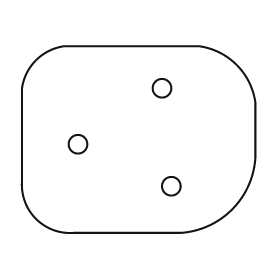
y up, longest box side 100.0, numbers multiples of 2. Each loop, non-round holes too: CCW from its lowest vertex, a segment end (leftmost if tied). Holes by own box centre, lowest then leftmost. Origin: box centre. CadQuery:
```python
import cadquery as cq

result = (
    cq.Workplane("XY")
    .moveTo(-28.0, -40.0)
    .lineTo(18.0, -40.0)
    .threePointArc((40.0, -30.0), (50.0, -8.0))
    .lineTo(50.0, 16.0)
    .threePointArc((42.0, 32.0), (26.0, 40.0))
    .lineTo(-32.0, 40.0)
    .threePointArc((-44.0, 34.0), (-50.0, 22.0))
    .lineTo(-50.0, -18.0)
    .threePointArc((-44.0, -34.0), (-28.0, -40.0))
    .close()
    .moveTo(14.0, -20.0)
    .circle(4.0)
    .moveTo(-26.0, -2.0)
    .circle(4.0)
    .moveTo(10.0, 22.0)
    .circle(4.0)
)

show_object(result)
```